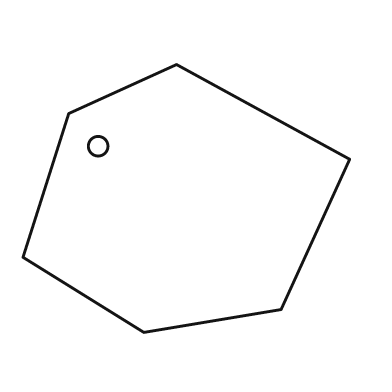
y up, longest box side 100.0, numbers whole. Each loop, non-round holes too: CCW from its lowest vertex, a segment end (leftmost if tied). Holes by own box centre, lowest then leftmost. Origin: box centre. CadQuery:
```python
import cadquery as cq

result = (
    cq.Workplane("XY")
    .moveTo(-13.0, -41.0)
    .lineTo(29.0, -34.0)
    .lineTo(50.0, 12.0)
    .lineTo(-3.0, 41.0)
    .lineTo(-36.0, 26.0)
    .lineTo(-50.0, -18.0)
    .close()
    .moveTo(-27.0, 16.0)
    .circle(3.0)
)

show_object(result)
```